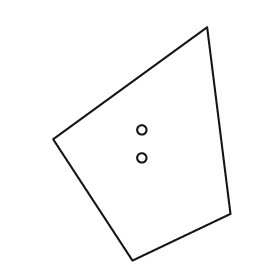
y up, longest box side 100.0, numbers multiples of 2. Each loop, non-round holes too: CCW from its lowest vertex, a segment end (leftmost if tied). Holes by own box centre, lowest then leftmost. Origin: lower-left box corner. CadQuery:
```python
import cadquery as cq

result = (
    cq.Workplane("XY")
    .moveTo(34.0, 0.0)
    .lineTo(76.0, 20.0)
    .lineTo(66.0, 100.0)
    .lineTo(0.0, 52.0)
    .close()
    .moveTo(38.0, 44.0)
    .circle(2.0)
    .moveTo(38.0, 56.0)
    .circle(2.0)
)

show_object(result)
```